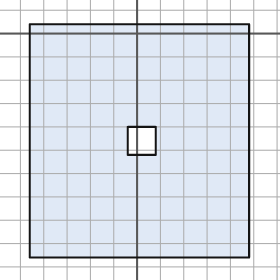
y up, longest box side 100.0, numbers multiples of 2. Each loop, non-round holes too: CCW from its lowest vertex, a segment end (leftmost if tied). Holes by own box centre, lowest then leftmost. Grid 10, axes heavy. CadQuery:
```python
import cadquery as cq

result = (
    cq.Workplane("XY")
    .moveTo(-46.0, -96.0)
    .lineTo(48.0, -96.0)
    .lineTo(48.0, 4.0)
    .lineTo(-46.0, 4.0)
    .close()
    .moveTo(-4.0, -52.0)
    .lineTo(8.0, -52.0)
    .lineTo(8.0, -40.0)
    .lineTo(-4.0, -40.0)
    .close()
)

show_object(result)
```